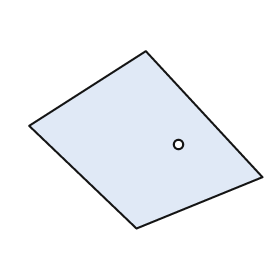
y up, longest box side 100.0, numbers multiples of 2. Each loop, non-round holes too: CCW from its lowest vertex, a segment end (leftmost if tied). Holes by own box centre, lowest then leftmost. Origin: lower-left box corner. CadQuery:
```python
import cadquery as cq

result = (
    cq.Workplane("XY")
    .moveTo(46.0, 0.0)
    .lineTo(100.0, 22.0)
    .lineTo(50.0, 76.0)
    .lineTo(0.0, 44.0)
    .close()
    .moveTo(64.0, 36.0)
    .circle(2.0)
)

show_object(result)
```